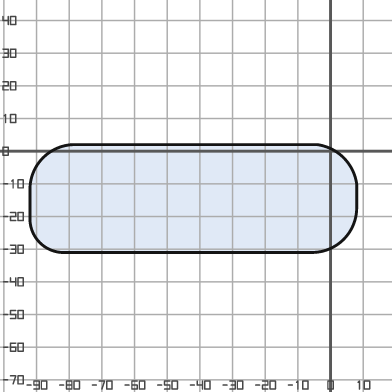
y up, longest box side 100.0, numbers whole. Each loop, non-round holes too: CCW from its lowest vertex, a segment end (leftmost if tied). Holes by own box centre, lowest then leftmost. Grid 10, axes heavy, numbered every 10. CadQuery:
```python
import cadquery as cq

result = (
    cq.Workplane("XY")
    .moveTo(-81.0, -31.0)
    .lineTo(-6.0, -31.0)
    .threePointArc((4.0, -27.0), (8.0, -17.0))
    .lineTo(8.0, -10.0)
    .threePointArc((4.0, -2.0), (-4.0, 2.0))
    .lineTo(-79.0, 2.0)
    .threePointArc((-88.0, -2.0), (-92.0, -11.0))
    .lineTo(-92.0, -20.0)
    .threePointArc((-89.0, -28.0), (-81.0, -31.0))
    .close()
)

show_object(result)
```